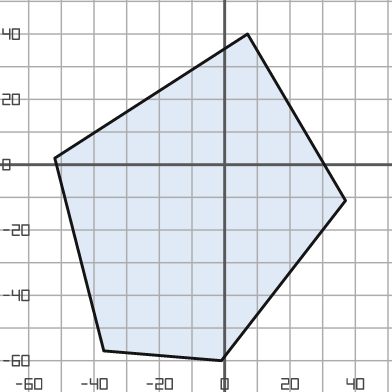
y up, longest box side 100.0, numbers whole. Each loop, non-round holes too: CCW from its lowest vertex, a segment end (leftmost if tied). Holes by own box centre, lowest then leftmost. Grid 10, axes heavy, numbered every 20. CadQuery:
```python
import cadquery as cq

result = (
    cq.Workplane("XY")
    .moveTo(-1.0, -60.0)
    .lineTo(37.0, -11.0)
    .lineTo(7.0, 40.0)
    .lineTo(-52.0, 2.0)
    .lineTo(-37.0, -57.0)
    .close()
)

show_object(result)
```